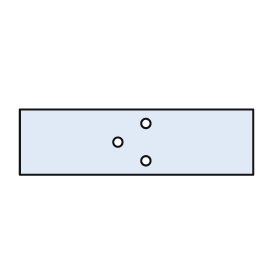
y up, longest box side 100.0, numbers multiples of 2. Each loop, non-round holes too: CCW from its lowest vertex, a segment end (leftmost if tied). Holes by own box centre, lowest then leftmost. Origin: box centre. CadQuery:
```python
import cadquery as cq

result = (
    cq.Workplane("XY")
    .moveTo(-50.0, -14.0)
    .lineTo(50.0, -14.0)
    .lineTo(50.0, 14.0)
    .lineTo(-50.0, 14.0)
    .close()
    .moveTo(4.0, -8.0)
    .circle(2.0)
    .moveTo(-8.0, 0.0)
    .circle(2.0)
    .moveTo(4.0, 8.0)
    .circle(2.0)
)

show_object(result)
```